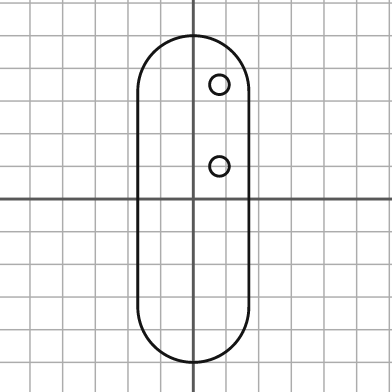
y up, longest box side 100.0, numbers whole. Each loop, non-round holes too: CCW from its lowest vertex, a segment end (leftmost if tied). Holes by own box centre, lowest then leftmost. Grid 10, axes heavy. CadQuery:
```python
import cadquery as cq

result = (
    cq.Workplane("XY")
    .moveTo(-17.0, -33.0)
    .threePointArc((0.0, -50.0), (17.0, -33.0))
    .lineTo(17.0, 33.0)
    .threePointArc((0.0, 50.0), (-17.0, 33.0))
    .close()
    .moveTo(8.0, 10.0)
    .circle(3.0)
    .moveTo(8.0, 35.0)
    .circle(3.0)
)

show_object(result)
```